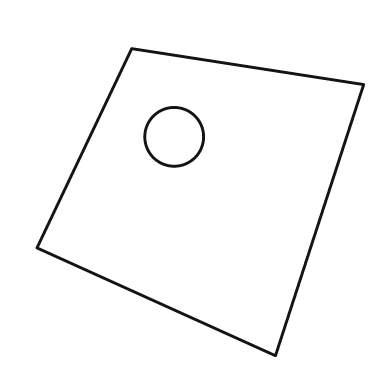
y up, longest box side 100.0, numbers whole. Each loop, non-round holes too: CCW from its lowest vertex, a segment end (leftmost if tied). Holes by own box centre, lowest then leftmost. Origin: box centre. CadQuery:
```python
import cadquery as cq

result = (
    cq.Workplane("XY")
    .moveTo(23.0, -47.0)
    .lineTo(50.0, 36.0)
    .lineTo(-21.0, 47.0)
    .lineTo(-50.0, -14.0)
    .close()
    .moveTo(-8.0, 20.0)
    .circle(9.0)
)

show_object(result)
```